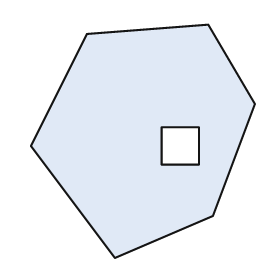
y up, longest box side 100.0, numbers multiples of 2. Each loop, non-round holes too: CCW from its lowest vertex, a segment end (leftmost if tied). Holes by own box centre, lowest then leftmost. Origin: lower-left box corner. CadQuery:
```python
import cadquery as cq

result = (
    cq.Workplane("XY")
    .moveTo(36.0, 0.0)
    .lineTo(78.0, 18.0)
    .lineTo(96.0, 66.0)
    .lineTo(76.0, 100.0)
    .lineTo(24.0, 96.0)
    .lineTo(0.0, 48.0)
    .close()
    .moveTo(56.0, 40.0)
    .lineTo(72.0, 40.0)
    .lineTo(72.0, 56.0)
    .lineTo(56.0, 56.0)
    .close()
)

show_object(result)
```